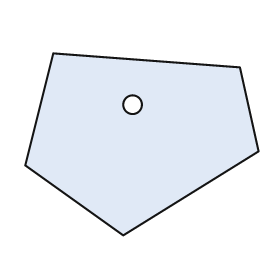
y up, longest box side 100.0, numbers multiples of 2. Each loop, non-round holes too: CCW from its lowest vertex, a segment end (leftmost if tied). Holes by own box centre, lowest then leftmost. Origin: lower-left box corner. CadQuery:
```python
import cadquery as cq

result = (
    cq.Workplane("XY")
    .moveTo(42.0, 0.0)
    .lineTo(100.0, 36.0)
    .lineTo(92.0, 72.0)
    .lineTo(12.0, 78.0)
    .lineTo(0.0, 30.0)
    .close()
    .moveTo(46.0, 56.0)
    .circle(4.0)
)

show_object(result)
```